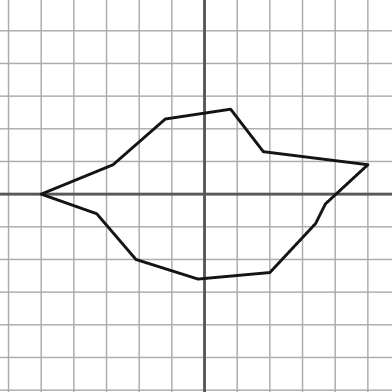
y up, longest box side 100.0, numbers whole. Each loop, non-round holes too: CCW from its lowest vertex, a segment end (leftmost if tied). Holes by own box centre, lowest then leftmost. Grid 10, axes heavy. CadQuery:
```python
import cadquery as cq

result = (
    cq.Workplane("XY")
    .moveTo(-2.0, -26.0)
    .lineTo(20.0, -24.0)
    .lineTo(34.0, -9.0)
    .lineTo(37.0, -3.0)
    .lineTo(50.0, 9.0)
    .lineTo(18.0, 13.0)
    .lineTo(8.0, 26.0)
    .lineTo(-12.0, 23.0)
    .lineTo(-28.0, 9.0)
    .lineTo(-50.0, 0.0)
    .lineTo(-33.0, -6.0)
    .lineTo(-21.0, -20.0)
    .close()
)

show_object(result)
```